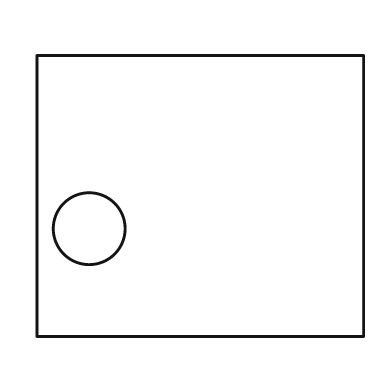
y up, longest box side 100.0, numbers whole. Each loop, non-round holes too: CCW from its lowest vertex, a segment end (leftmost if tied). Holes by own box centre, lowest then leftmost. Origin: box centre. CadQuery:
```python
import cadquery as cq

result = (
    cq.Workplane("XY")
    .moveTo(-50.0, -43.0)
    .lineTo(50.0, -43.0)
    .lineTo(50.0, 43.0)
    .lineTo(-50.0, 43.0)
    .close()
    .moveTo(-34.0, -10.0)
    .circle(11.0)
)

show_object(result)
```